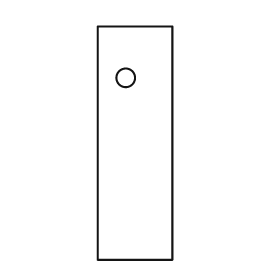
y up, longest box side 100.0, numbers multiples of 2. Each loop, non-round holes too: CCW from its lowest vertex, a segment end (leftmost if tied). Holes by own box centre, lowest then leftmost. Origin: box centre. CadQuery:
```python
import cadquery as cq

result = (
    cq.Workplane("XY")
    .moveTo(-16.0, -50.0)
    .lineTo(16.0, -50.0)
    .lineTo(16.0, 50.0)
    .lineTo(-16.0, 50.0)
    .close()
    .moveTo(-4.0, 28.0)
    .circle(4.0)
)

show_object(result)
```